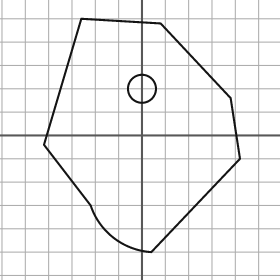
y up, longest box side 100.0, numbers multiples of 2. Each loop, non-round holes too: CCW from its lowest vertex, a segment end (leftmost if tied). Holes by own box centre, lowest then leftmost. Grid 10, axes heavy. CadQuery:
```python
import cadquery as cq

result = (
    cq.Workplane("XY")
    .moveTo(4.0, -50.0)
    .lineTo(42.0, -10.0)
    .lineTo(38.0, 16.0)
    .lineTo(8.0, 48.0)
    .lineTo(-26.0, 50.0)
    .lineTo(-42.0, -4.0)
    .lineTo(-22.0, -30.0)
    .threePointArc((-12.0, -44.0), (4.0, -50.0))
    .close()
    .moveTo(0.0, 20.0)
    .circle(6.0)
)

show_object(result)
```